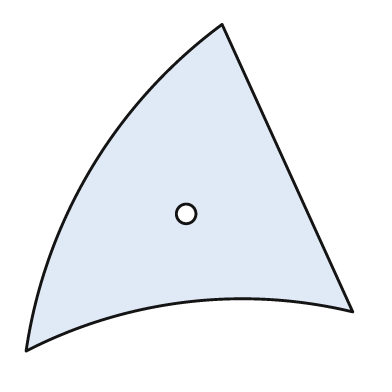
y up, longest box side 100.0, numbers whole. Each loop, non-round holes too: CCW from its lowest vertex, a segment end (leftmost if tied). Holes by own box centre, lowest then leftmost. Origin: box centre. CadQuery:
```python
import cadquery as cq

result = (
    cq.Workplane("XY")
    .moveTo(-50.0, -50.0)
    .threePointArc((-1.0, -35.0), (50.0, -38.0))
    .lineTo(10.0, 50.0)
    .threePointArc((-30.0, 6.0), (-50.0, -50.0))
    .close()
    .moveTo(-1.0, -8.0)
    .circle(3.0)
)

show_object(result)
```